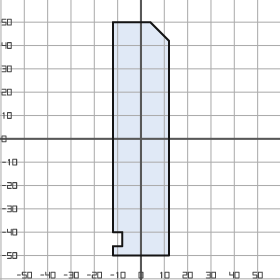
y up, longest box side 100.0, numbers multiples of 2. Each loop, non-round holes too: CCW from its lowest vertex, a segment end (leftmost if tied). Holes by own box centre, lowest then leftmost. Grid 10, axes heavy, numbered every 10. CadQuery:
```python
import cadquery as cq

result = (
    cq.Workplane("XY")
    .moveTo(-12.0, -50.0)
    .lineTo(12.0, -50.0)
    .lineTo(12.0, 42.0)
    .lineTo(4.0, 50.0)
    .lineTo(-12.0, 50.0)
    .lineTo(-12.0, -40.0)
    .lineTo(-8.0, -40.0)
    .lineTo(-8.0, -46.0)
    .lineTo(-12.0, -46.0)
    .close()
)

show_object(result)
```